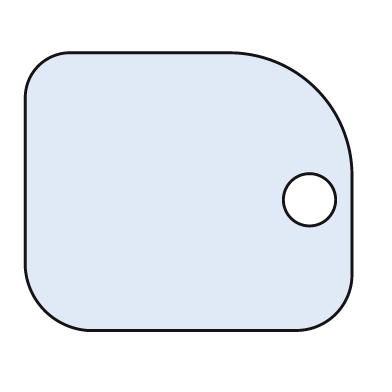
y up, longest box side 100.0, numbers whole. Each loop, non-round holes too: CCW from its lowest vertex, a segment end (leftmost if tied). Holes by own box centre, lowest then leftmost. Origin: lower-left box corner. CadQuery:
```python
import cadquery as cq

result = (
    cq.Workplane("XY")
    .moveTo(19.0, 0.0)
    .lineTo(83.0, 0.0)
    .threePointArc((95.0, 5.0), (100.0, 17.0))
    .lineTo(100.0, 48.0)
    .threePointArc((89.0, 74.0), (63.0, 85.0))
    .lineTo(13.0, 85.0)
    .threePointArc((4.0, 81.0), (0.0, 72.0))
    .lineTo(0.0, 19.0)
    .threePointArc((6.0, 6.0), (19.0, 0.0))
    .close()
    .moveTo(87.0, 40.0)
    .circle(8.0)
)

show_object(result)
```